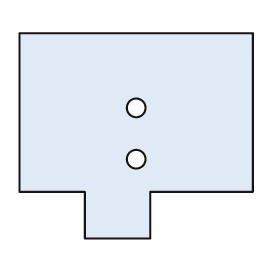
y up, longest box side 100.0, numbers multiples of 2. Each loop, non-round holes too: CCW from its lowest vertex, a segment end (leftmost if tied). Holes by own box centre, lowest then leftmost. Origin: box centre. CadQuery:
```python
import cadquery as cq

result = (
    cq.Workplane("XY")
    .moveTo(-22.0, -44.0)
    .lineTo(6.0, -44.0)
    .lineTo(6.0, -24.0)
    .lineTo(50.0, -24.0)
    .lineTo(50.0, 44.0)
    .lineTo(-50.0, 44.0)
    .lineTo(-50.0, -24.0)
    .lineTo(-22.0, -24.0)
    .close()
    .moveTo(0.0, -10.0)
    .circle(4.0)
    .moveTo(0.0, 12.0)
    .circle(4.0)
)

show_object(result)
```